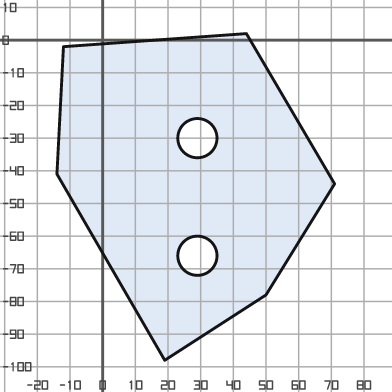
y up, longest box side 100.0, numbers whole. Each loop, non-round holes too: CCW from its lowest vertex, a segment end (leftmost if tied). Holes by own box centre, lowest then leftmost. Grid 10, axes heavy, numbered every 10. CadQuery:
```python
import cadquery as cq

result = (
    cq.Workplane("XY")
    .moveTo(19.0, -98.0)
    .lineTo(50.0, -78.0)
    .lineTo(71.0, -44.0)
    .lineTo(44.0, 2.0)
    .lineTo(-12.0, -2.0)
    .lineTo(-14.0, -41.0)
    .close()
    .moveTo(29.0, -66.0)
    .circle(6.0)
    .moveTo(29.0, -30.0)
    .circle(6.0)
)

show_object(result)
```